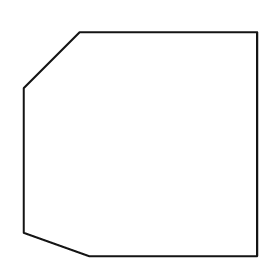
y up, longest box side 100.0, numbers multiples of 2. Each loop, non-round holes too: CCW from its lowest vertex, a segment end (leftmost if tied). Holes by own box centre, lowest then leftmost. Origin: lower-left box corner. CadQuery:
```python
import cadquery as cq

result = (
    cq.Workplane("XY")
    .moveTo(28.0, 0.0)
    .lineTo(100.0, 0.0)
    .lineTo(100.0, 96.0)
    .lineTo(24.0, 96.0)
    .lineTo(0.0, 72.0)
    .lineTo(0.0, 10.0)
    .close()
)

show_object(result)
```